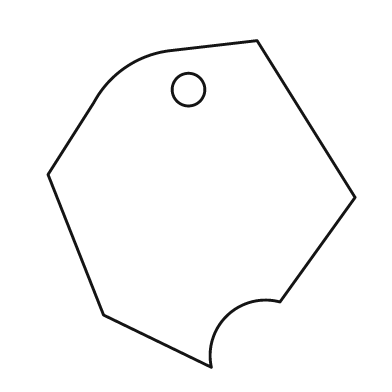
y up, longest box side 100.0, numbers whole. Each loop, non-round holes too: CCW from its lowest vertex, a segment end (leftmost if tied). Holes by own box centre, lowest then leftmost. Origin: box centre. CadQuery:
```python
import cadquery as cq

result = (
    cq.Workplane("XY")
    .moveTo(3.0, -50.0)
    .threePointArc((8.0, -34.0), (24.0, -30.0))
    .lineTo(47.0, 2.0)
    .lineTo(17.0, 50.0)
    .lineTo(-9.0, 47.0)
    .threePointArc((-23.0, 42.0), (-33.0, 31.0))
    .lineTo(-47.0, 9.0)
    .lineTo(-30.0, -34.0)
    .close()
    .moveTo(-4.0, 35.0)
    .circle(5.0)
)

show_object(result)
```